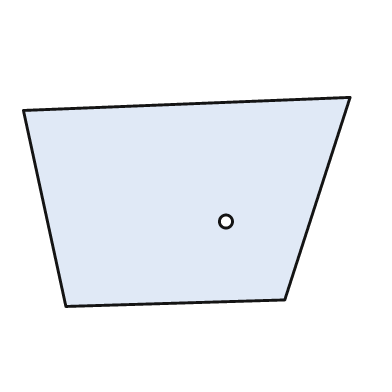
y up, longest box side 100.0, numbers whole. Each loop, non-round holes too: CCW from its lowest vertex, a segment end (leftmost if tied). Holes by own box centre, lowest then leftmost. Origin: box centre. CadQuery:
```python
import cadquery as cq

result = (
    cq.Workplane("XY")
    .moveTo(-37.0, -32.0)
    .lineTo(30.0, -30.0)
    .lineTo(50.0, 32.0)
    .lineTo(-50.0, 28.0)
    .close()
    .moveTo(12.0, -6.0)
    .circle(2.0)
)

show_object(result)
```